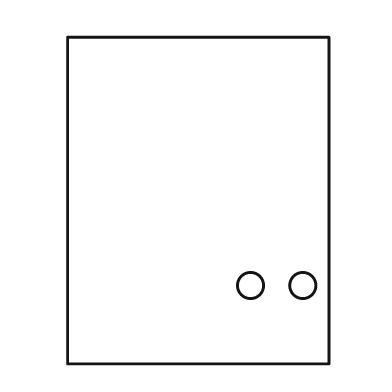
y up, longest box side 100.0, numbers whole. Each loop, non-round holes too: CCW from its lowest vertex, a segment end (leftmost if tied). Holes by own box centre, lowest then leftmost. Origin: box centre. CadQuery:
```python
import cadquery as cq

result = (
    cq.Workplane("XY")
    .moveTo(-40.0, -50.0)
    .lineTo(40.0, -50.0)
    .lineTo(40.0, 50.0)
    .lineTo(-40.0, 50.0)
    .close()
    .moveTo(16.0, -26.0)
    .circle(4.0)
    .moveTo(32.0, -26.0)
    .circle(4.0)
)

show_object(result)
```